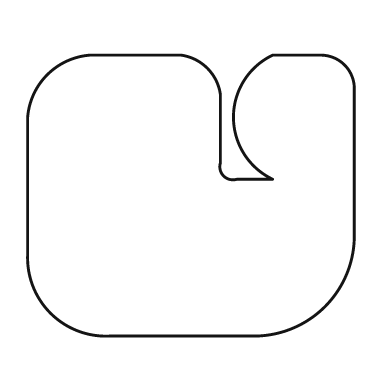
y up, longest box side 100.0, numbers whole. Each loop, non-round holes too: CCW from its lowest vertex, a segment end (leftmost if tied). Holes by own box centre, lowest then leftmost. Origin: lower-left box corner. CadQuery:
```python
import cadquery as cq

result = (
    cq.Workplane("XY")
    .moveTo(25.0, 0.0)
    .lineTo(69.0, 0.0)
    .threePointArc((91.0, 9.0), (100.0, 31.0))
    .lineTo(100.0, 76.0)
    .threePointArc((97.0, 83.0), (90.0, 86.0))
    .lineTo(75.0, 86.0)
    .threePointArc((63.0, 67.0), (75.0, 48.0))
    .lineTo(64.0, 48.0)
    .threePointArc((60.0, 49.0), (59.0, 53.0))
    .lineTo(59.0, 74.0)
    .threePointArc((55.0, 82.0), (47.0, 86.0))
    .lineTo(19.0, 86.0)
    .threePointArc((6.0, 80.0), (0.0, 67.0))
    .lineTo(0.0, 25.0)
    .threePointArc((7.0, 7.0), (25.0, 0.0))
    .close()
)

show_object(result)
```